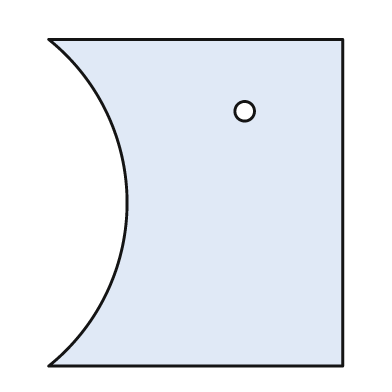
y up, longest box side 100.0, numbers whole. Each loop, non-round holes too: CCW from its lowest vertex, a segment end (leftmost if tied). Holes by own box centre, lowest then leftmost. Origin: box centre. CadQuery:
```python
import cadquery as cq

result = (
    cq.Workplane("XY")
    .moveTo(-45.0, -50.0)
    .lineTo(45.0, -50.0)
    .lineTo(45.0, 50.0)
    .lineTo(-45.0, 50.0)
    .threePointArc((-21.0, 0.0), (-45.0, -50.0))
    .close()
    .moveTo(15.0, 28.0)
    .circle(3.0)
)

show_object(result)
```